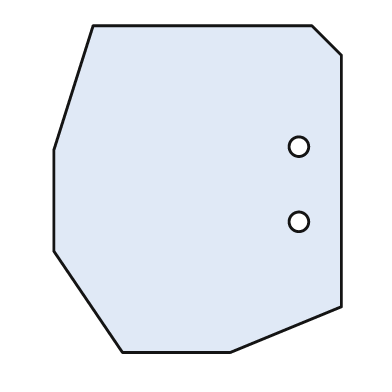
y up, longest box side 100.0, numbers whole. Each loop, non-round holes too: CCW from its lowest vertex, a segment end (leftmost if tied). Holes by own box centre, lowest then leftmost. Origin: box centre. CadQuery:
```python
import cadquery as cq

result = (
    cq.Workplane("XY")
    .moveTo(-23.0, -50.0)
    .lineTo(10.0, -50.0)
    .lineTo(44.0, -36.0)
    .lineTo(44.0, 41.0)
    .lineTo(35.0, 50.0)
    .lineTo(-32.0, 50.0)
    .lineTo(-44.0, 12.0)
    .lineTo(-44.0, -19.0)
    .close()
    .moveTo(31.0, -10.0)
    .circle(3.0)
    .moveTo(31.0, 13.0)
    .circle(3.0)
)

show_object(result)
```